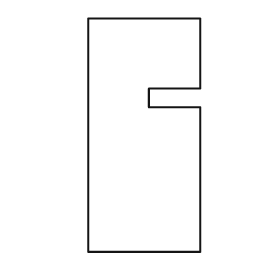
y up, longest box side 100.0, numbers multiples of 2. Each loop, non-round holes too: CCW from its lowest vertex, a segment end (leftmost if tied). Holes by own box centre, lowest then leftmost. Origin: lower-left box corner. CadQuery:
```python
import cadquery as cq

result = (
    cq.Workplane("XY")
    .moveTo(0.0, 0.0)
    .lineTo(48.0, 0.0)
    .lineTo(48.0, 62.0)
    .lineTo(26.0, 62.0)
    .lineTo(26.0, 70.0)
    .lineTo(48.0, 70.0)
    .lineTo(48.0, 100.0)
    .lineTo(0.0, 100.0)
    .close()
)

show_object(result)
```